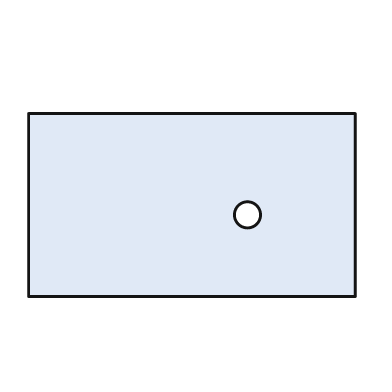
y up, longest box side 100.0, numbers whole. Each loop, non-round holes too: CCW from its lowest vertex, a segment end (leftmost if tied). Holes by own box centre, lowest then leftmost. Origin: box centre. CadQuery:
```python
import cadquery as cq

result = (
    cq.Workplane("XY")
    .moveTo(-50.0, -28.0)
    .lineTo(50.0, -28.0)
    .lineTo(50.0, 28.0)
    .lineTo(-50.0, 28.0)
    .close()
    .moveTo(17.0, -3.0)
    .circle(4.0)
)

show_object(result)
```